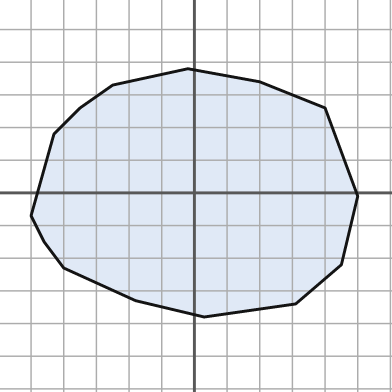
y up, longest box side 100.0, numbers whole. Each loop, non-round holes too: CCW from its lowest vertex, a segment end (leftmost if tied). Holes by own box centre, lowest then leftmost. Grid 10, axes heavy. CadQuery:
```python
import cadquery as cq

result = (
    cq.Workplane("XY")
    .moveTo(3.0, -38.0)
    .lineTo(31.0, -34.0)
    .lineTo(45.0, -22.0)
    .lineTo(50.0, -1.0)
    .lineTo(40.0, 26.0)
    .lineTo(20.0, 34.0)
    .lineTo(-2.0, 38.0)
    .lineTo(-25.0, 33.0)
    .lineTo(-35.0, 26.0)
    .lineTo(-43.0, 18.0)
    .lineTo(-50.0, -7.0)
    .lineTo(-46.0, -15.0)
    .lineTo(-40.0, -23.0)
    .lineTo(-18.0, -33.0)
    .close()
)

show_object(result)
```